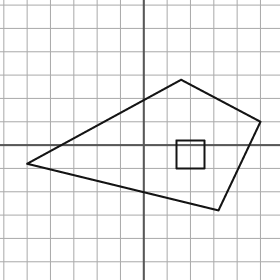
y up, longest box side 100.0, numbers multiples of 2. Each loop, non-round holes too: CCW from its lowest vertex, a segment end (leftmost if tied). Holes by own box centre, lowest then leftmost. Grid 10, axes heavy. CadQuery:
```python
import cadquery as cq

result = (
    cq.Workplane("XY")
    .moveTo(32.0, -28.0)
    .lineTo(50.0, 10.0)
    .lineTo(16.0, 28.0)
    .lineTo(-50.0, -8.0)
    .close()
    .moveTo(14.0, -10.0)
    .lineTo(26.0, -10.0)
    .lineTo(26.0, 2.0)
    .lineTo(14.0, 2.0)
    .close()
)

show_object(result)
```